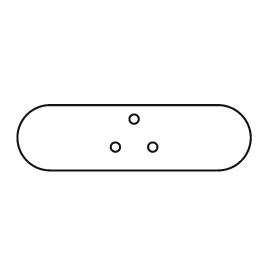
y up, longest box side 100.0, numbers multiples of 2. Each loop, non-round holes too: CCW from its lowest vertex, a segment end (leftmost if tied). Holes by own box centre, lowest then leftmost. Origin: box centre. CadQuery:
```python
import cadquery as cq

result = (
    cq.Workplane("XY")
    .moveTo(-36.0, -14.0)
    .lineTo(36.0, -14.0)
    .threePointArc((50.0, 0.0), (36.0, 14.0))
    .lineTo(-36.0, 14.0)
    .threePointArc((-50.0, 0.0), (-36.0, -14.0))
    .close()
    .moveTo(-8.0, -4.0)
    .circle(2.0)
    .moveTo(8.0, -4.0)
    .circle(2.0)
    .moveTo(0.0, 8.0)
    .circle(2.0)
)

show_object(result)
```